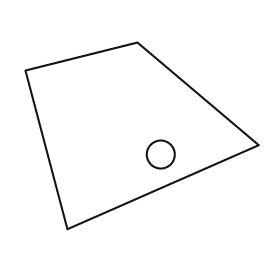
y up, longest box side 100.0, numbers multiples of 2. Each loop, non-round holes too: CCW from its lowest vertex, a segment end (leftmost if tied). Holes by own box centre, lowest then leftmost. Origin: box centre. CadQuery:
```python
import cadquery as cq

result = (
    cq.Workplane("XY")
    .moveTo(-32.0, -40.0)
    .lineTo(50.0, -4.0)
    .lineTo(-2.0, 40.0)
    .lineTo(-50.0, 28.0)
    .close()
    .moveTo(8.0, -8.0)
    .circle(6.0)
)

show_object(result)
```